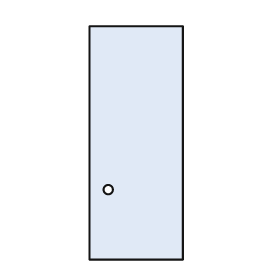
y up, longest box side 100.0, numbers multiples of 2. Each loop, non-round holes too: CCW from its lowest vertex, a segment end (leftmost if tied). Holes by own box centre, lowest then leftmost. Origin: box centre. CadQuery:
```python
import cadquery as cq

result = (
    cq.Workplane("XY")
    .moveTo(-20.0, -50.0)
    .lineTo(20.0, -50.0)
    .lineTo(20.0, 50.0)
    .lineTo(-20.0, 50.0)
    .close()
    .moveTo(-12.0, -20.0)
    .circle(2.0)
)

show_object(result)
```